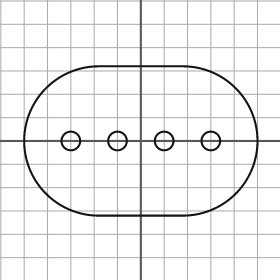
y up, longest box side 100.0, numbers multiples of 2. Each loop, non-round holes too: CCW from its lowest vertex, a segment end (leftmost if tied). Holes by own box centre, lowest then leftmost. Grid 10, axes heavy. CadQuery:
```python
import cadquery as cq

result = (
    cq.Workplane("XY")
    .moveTo(-18.0, -32.0)
    .lineTo(18.0, -32.0)
    .threePointArc((50.0, 0.0), (18.0, 32.0))
    .lineTo(-18.0, 32.0)
    .threePointArc((-50.0, 0.0), (-18.0, -32.0))
    .close()
    .moveTo(-30.0, 0.0)
    .circle(4.0)
    .moveTo(-10.0, 0.0)
    .circle(4.0)
    .moveTo(10.0, 0.0)
    .circle(4.0)
    .moveTo(30.0, 0.0)
    .circle(4.0)
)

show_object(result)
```